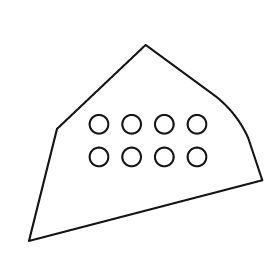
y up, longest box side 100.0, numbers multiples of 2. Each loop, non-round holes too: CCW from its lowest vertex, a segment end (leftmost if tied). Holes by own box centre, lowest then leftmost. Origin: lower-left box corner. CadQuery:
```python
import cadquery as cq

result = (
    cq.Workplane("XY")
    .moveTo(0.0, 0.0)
    .lineTo(100.0, 26.0)
    .lineTo(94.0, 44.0)
    .threePointArc((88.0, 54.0), (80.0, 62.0))
    .lineTo(50.0, 84.0)
    .lineTo(12.0, 48.0)
    .close()
    .moveTo(30.0, 36.0)
    .circle(4.0)
    .moveTo(44.0, 36.0)
    .circle(4.0)
    .moveTo(58.0, 36.0)
    .circle(4.0)
    .moveTo(72.0, 36.0)
    .circle(4.0)
    .moveTo(30.0, 50.0)
    .circle(4.0)
    .moveTo(44.0, 50.0)
    .circle(4.0)
    .moveTo(58.0, 50.0)
    .circle(4.0)
    .moveTo(72.0, 50.0)
    .circle(4.0)
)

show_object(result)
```